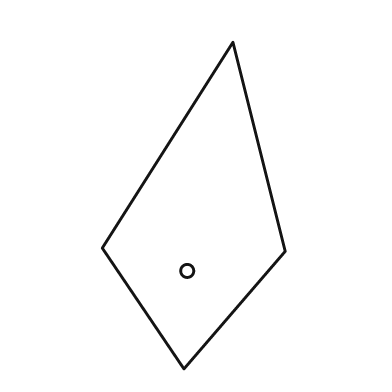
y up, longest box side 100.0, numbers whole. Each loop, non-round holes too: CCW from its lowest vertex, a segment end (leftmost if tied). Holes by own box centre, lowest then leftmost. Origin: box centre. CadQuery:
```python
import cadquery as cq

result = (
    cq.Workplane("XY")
    .moveTo(-3.0, -50.0)
    .lineTo(28.0, -14.0)
    .lineTo(12.0, 50.0)
    .lineTo(-28.0, -13.0)
    .close()
    .moveTo(-2.0, -20.0)
    .circle(2.0)
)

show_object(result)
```